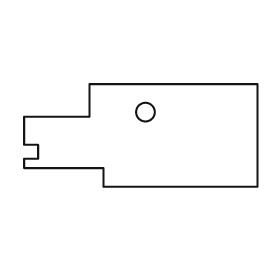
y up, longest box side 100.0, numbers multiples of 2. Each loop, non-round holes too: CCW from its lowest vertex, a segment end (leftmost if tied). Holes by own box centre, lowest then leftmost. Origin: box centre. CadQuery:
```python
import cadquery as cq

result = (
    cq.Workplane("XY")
    .moveTo(-16.0, -22.0)
    .lineTo(50.0, -22.0)
    .lineTo(50.0, 22.0)
    .lineTo(-22.0, 22.0)
    .lineTo(-22.0, 8.0)
    .lineTo(-50.0, 8.0)
    .lineTo(-50.0, -4.0)
    .lineTo(-44.0, -4.0)
    .lineTo(-44.0, -10.0)
    .lineTo(-50.0, -10.0)
    .lineTo(-50.0, -14.0)
    .lineTo(-16.0, -14.0)
    .close()
    .moveTo(2.0, 10.0)
    .circle(4.0)
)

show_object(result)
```